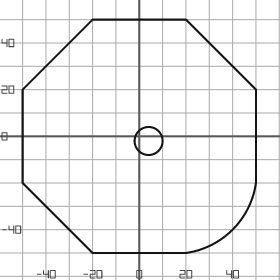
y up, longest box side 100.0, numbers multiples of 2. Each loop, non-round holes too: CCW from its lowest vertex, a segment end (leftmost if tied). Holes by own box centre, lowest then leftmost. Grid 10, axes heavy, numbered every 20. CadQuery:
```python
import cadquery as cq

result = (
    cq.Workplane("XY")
    .moveTo(-20.0, -50.0)
    .lineTo(20.0, -50.0)
    .threePointArc((40.0, -40.0), (50.0, -20.0))
    .lineTo(50.0, 20.0)
    .lineTo(20.0, 50.0)
    .lineTo(-20.0, 50.0)
    .lineTo(-50.0, 20.0)
    .lineTo(-50.0, -20.0)
    .close()
    .moveTo(4.0, -2.0)
    .circle(6.0)
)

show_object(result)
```